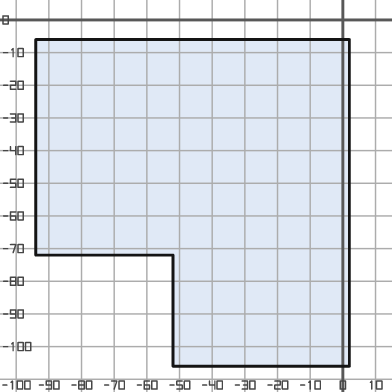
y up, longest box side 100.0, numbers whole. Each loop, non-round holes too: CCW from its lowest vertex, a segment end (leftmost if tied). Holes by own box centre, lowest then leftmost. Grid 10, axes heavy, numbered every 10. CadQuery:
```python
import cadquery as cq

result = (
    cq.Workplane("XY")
    .moveTo(-52.0, -106.0)
    .lineTo(2.0, -106.0)
    .lineTo(2.0, -6.0)
    .lineTo(-94.0, -6.0)
    .lineTo(-94.0, -72.0)
    .lineTo(-52.0, -72.0)
    .close()
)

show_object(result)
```